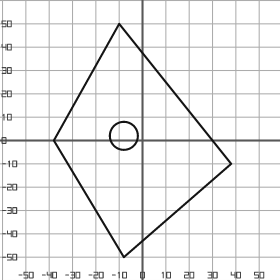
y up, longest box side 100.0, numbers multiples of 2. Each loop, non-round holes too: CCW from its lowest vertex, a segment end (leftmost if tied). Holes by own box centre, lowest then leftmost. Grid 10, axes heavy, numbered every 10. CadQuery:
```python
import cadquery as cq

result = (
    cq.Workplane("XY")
    .moveTo(-8.0, -50.0)
    .lineTo(38.0, -10.0)
    .lineTo(-10.0, 50.0)
    .lineTo(-38.0, 0.0)
    .close()
    .moveTo(-8.0, 2.0)
    .circle(6.0)
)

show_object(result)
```